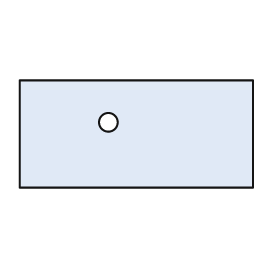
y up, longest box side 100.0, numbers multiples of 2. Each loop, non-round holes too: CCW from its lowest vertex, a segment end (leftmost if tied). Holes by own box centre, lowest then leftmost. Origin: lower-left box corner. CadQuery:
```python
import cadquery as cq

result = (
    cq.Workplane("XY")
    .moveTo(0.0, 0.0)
    .lineTo(100.0, 0.0)
    .lineTo(100.0, 46.0)
    .lineTo(0.0, 46.0)
    .close()
    .moveTo(38.0, 28.0)
    .circle(4.0)
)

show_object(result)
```